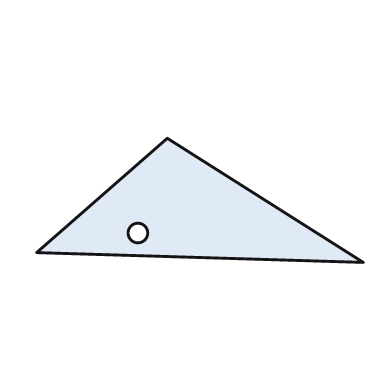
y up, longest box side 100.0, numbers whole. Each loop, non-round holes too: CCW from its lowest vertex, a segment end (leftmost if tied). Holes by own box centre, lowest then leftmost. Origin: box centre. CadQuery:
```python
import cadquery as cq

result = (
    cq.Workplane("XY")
    .moveTo(50.0, -19.0)
    .lineTo(-10.0, 19.0)
    .lineTo(-50.0, -16.0)
    .close()
    .moveTo(-19.0, -10.0)
    .circle(3.0)
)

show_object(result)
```